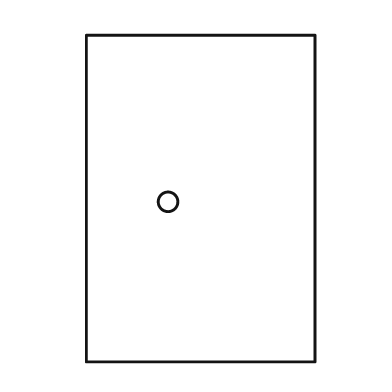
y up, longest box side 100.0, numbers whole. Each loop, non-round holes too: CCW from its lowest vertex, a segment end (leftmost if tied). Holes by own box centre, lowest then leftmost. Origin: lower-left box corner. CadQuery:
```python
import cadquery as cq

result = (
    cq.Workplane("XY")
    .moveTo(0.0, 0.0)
    .lineTo(70.0, 0.0)
    .lineTo(70.0, 100.0)
    .lineTo(0.0, 100.0)
    .close()
    .moveTo(25.0, 49.0)
    .circle(3.0)
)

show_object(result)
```